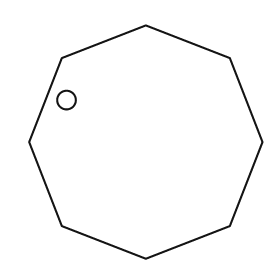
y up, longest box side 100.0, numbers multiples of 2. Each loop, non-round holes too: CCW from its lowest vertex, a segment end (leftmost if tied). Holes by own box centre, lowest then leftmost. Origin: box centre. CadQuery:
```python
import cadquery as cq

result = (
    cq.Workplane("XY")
    .moveTo(0.0, -50.0)
    .lineTo(36.0, -36.0)
    .lineTo(50.0, 0.0)
    .lineTo(36.0, 36.0)
    .lineTo(0.0, 50.0)
    .lineTo(-36.0, 36.0)
    .lineTo(-50.0, 0.0)
    .lineTo(-36.0, -36.0)
    .close()
    .moveTo(-34.0, 18.0)
    .circle(4.0)
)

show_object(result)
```